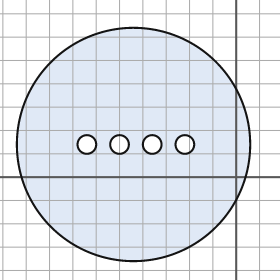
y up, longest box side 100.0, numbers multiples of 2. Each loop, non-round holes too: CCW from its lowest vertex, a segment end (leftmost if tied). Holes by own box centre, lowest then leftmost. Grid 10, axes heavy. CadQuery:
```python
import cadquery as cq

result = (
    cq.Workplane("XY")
    .moveTo(-44.0, 14.0)
    .circle(50.0)
    .moveTo(-64.0, 14.0)
    .circle(4.0)
    .moveTo(-50.0, 14.0)
    .circle(4.0)
    .moveTo(-36.0, 14.0)
    .circle(4.0)
    .moveTo(-22.0, 14.0)
    .circle(4.0)
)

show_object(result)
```